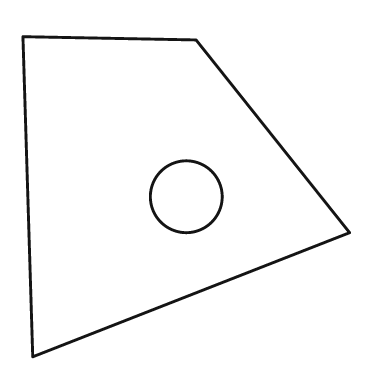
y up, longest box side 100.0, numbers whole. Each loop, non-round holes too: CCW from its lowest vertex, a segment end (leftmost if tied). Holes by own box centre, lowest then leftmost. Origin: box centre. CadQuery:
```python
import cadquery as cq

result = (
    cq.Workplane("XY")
    .moveTo(-47.0, -49.0)
    .lineTo(50.0, -11.0)
    .lineTo(3.0, 48.0)
    .lineTo(-50.0, 49.0)
    .close()
    .moveTo(0.0, 0.0)
    .circle(11.0)
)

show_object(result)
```